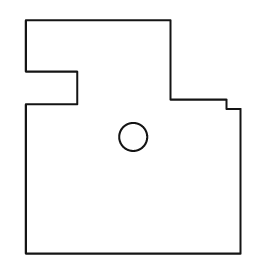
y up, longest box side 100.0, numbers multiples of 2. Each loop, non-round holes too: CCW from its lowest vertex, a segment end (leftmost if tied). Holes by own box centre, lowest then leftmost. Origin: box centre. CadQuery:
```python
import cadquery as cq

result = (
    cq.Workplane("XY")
    .moveTo(-46.0, -50.0)
    .lineTo(46.0, -50.0)
    .lineTo(46.0, 12.0)
    .lineTo(40.0, 12.0)
    .lineTo(40.0, 16.0)
    .lineTo(16.0, 16.0)
    .lineTo(16.0, 50.0)
    .lineTo(-46.0, 50.0)
    .lineTo(-46.0, 28.0)
    .lineTo(-24.0, 28.0)
    .lineTo(-24.0, 14.0)
    .lineTo(-46.0, 14.0)
    .close()
    .moveTo(0.0, 0.0)
    .circle(6.0)
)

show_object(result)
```